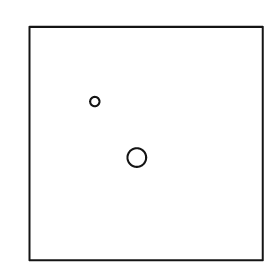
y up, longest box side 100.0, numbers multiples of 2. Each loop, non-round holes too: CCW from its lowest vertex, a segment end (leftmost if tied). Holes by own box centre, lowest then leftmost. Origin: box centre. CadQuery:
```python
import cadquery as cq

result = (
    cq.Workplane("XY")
    .moveTo(-50.0, -50.0)
    .lineTo(50.0, -50.0)
    .lineTo(50.0, 50.0)
    .lineTo(-50.0, 50.0)
    .close()
    .moveTo(-4.0, -6.0)
    .circle(4.0)
    .moveTo(-22.0, 18.0)
    .circle(2.0)
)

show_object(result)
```